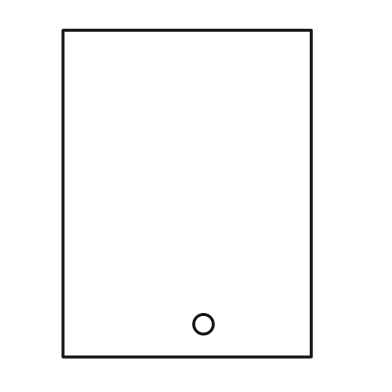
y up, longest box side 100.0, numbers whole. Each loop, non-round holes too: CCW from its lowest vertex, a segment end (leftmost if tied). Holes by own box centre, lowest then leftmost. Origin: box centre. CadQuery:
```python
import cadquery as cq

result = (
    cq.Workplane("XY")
    .moveTo(-38.0, -50.0)
    .lineTo(38.0, -50.0)
    .lineTo(38.0, 50.0)
    .lineTo(-38.0, 50.0)
    .close()
    .moveTo(5.0, -40.0)
    .circle(3.0)
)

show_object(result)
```